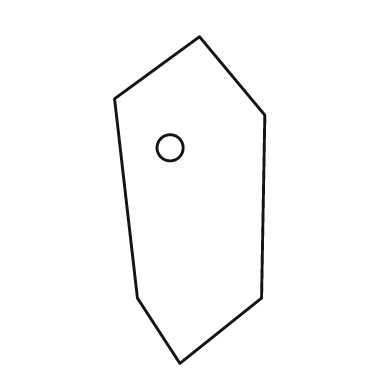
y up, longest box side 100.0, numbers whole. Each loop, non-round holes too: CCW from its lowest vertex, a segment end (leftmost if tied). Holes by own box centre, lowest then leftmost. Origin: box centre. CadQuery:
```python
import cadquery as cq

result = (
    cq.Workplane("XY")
    .moveTo(-3.0, -50.0)
    .lineTo(22.0, -30.0)
    .lineTo(23.0, 26.0)
    .lineTo(3.0, 50.0)
    .lineTo(-23.0, 31.0)
    .lineTo(-16.0, -30.0)
    .close()
    .moveTo(-6.0, 16.0)
    .circle(4.0)
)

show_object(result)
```